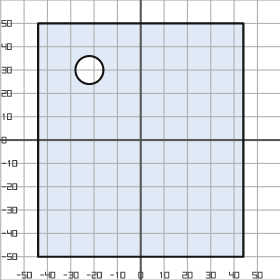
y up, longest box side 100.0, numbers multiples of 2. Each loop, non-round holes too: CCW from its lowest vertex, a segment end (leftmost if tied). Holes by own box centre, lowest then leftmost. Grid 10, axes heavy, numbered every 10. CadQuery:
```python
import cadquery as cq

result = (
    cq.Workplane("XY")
    .moveTo(-44.0, -50.0)
    .lineTo(44.0, -50.0)
    .lineTo(44.0, 50.0)
    .lineTo(-44.0, 50.0)
    .close()
    .moveTo(-22.0, 30.0)
    .circle(6.0)
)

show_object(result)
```